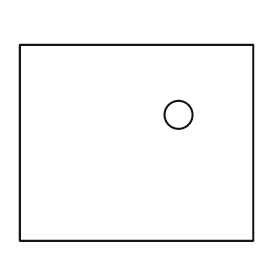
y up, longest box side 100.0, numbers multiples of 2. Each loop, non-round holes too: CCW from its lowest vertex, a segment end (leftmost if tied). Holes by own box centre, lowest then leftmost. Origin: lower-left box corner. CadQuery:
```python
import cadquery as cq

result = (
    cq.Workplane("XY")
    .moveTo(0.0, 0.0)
    .lineTo(100.0, 0.0)
    .lineTo(100.0, 84.0)
    .lineTo(0.0, 84.0)
    .close()
    .moveTo(68.0, 54.0)
    .circle(6.0)
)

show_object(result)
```